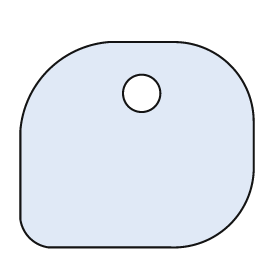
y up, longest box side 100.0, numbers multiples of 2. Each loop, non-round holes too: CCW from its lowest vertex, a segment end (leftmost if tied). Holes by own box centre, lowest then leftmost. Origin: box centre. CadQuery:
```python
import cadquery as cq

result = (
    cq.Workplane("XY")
    .moveTo(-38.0, -44.0)
    .lineTo(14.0, -44.0)
    .threePointArc((40.0, -34.0), (50.0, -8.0))
    .lineTo(50.0, 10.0)
    .threePointArc((40.0, 34.0), (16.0, 44.0))
    .lineTo(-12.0, 44.0)
    .threePointArc((-38.0, 32.0), (-50.0, 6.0))
    .lineTo(-50.0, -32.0)
    .threePointArc((-46.0, -40.0), (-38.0, -44.0))
    .close()
    .moveTo(2.0, 22.0)
    .circle(8.0)
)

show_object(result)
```